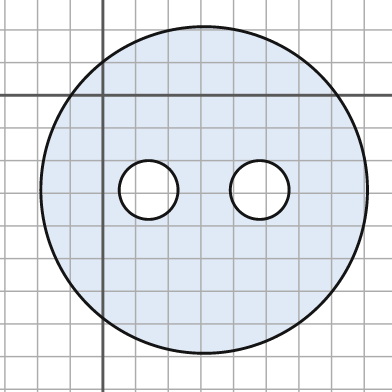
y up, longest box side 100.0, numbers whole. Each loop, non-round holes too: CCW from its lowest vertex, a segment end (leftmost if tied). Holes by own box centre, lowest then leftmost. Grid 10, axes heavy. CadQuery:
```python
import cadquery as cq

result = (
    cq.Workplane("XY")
    .moveTo(31.0, -29.0)
    .circle(50.0)
    .moveTo(14.0, -29.0)
    .circle(9.0)
    .moveTo(48.0, -29.0)
    .circle(9.0)
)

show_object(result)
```